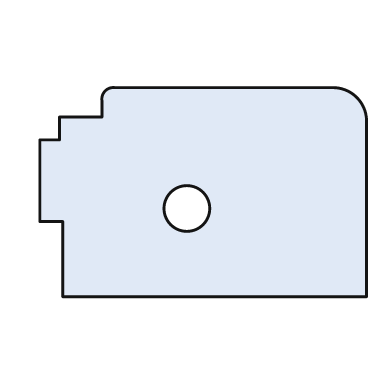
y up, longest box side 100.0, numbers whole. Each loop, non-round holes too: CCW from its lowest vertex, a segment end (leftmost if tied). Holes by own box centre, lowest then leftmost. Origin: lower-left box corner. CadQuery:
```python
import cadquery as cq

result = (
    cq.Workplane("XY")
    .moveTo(7.0, 0.0)
    .lineTo(100.0, 0.0)
    .lineTo(100.0, 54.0)
    .threePointArc((97.0, 61.0), (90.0, 64.0))
    .lineTo(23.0, 64.0)
    .threePointArc((20.0, 63.0), (19.0, 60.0))
    .lineTo(19.0, 55.0)
    .lineTo(6.0, 55.0)
    .lineTo(6.0, 48.0)
    .lineTo(0.0, 48.0)
    .lineTo(0.0, 23.0)
    .lineTo(7.0, 23.0)
    .close()
    .moveTo(45.0, 27.0)
    .circle(7.0)
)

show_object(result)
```